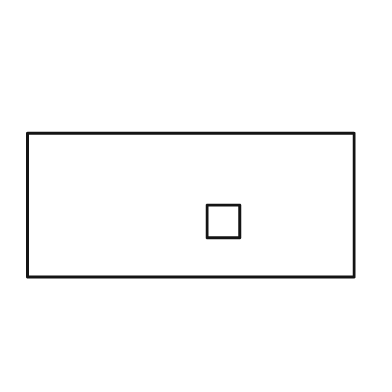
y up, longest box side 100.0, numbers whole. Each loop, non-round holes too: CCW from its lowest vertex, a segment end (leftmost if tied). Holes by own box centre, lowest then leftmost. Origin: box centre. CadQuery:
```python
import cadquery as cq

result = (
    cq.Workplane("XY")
    .moveTo(-50.0, -22.0)
    .lineTo(50.0, -22.0)
    .lineTo(50.0, 22.0)
    .lineTo(-50.0, 22.0)
    .close()
    .moveTo(5.0, -10.0)
    .lineTo(15.0, -10.0)
    .lineTo(15.0, 0.0)
    .lineTo(5.0, 0.0)
    .close()
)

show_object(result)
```